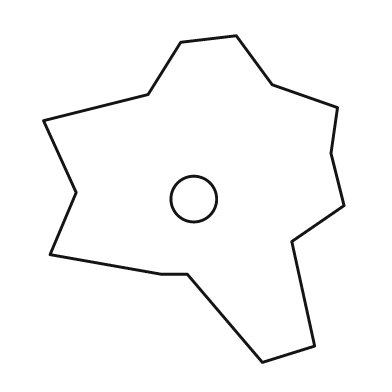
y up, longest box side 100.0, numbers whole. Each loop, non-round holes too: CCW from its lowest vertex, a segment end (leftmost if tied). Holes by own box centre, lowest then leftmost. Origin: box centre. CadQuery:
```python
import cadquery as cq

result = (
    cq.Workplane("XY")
    .moveTo(21.0, -50.0)
    .lineTo(37.0, -45.0)
    .lineTo(30.0, -13.0)
    .lineTo(46.0, -2.0)
    .lineTo(42.0, 14.0)
    .lineTo(44.0, 28.0)
    .lineTo(24.0, 35.0)
    .lineTo(13.0, 50.0)
    .lineTo(-4.0, 48.0)
    .lineTo(-14.0, 32.0)
    .lineTo(-46.0, 24.0)
    .lineTo(-36.0, 2.0)
    .lineTo(-44.0, -17.0)
    .lineTo(-10.0, -23.0)
    .lineTo(-2.0, -23.0)
    .close()
    .moveTo(0.0, 0.0)
    .circle(7.0)
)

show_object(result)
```